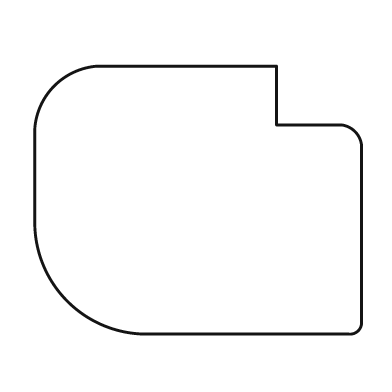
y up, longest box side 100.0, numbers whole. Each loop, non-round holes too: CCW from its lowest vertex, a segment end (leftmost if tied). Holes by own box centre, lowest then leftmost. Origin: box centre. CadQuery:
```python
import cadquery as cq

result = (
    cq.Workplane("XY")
    .moveTo(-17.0, -41.0)
    .lineTo(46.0, -41.0)
    .threePointArc((49.0, -40.0), (50.0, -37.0))
    .lineTo(50.0, 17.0)
    .threePointArc((48.0, 21.0), (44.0, 23.0))
    .lineTo(24.0, 23.0)
    .lineTo(24.0, 41.0)
    .lineTo(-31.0, 41.0)
    .threePointArc((-44.0, 35.0), (-50.0, 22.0))
    .lineTo(-50.0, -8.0)
    .threePointArc((-40.0, -31.0), (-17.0, -41.0))
    .close()
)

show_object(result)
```